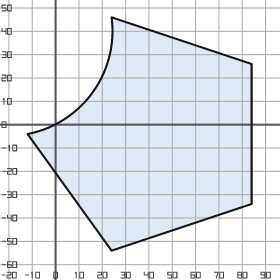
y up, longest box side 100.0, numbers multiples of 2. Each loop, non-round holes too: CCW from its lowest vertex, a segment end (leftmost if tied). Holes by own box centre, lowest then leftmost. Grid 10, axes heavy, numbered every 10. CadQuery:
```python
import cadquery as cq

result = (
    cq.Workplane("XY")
    .moveTo(24.0, -54.0)
    .lineTo(84.0, -34.0)
    .lineTo(84.0, 26.0)
    .lineTo(24.0, 46.0)
    .threePointArc((16.0, 14.0), (-12.0, -4.0))
    .close()
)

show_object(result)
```